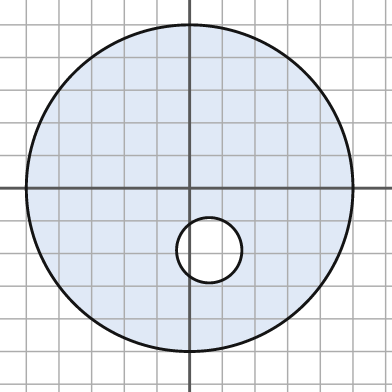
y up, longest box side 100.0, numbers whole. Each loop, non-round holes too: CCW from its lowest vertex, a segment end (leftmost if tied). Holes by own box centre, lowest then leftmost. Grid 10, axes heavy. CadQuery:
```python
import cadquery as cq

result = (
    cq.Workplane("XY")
    .moveTo(0.0, 0.0)
    .circle(50.0)
    .moveTo(6.0, -19.0)
    .circle(10.0)
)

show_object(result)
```